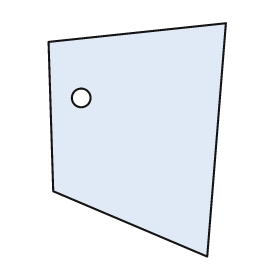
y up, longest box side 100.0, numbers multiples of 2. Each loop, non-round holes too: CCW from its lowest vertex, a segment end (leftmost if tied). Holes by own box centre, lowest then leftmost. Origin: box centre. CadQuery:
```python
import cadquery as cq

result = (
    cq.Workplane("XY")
    .moveTo(30.0, -50.0)
    .lineTo(38.0, 50.0)
    .lineTo(-38.0, 42.0)
    .lineTo(-36.0, -22.0)
    .close()
    .moveTo(-24.0, 18.0)
    .circle(4.0)
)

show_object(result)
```